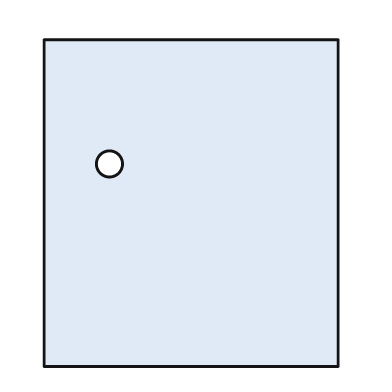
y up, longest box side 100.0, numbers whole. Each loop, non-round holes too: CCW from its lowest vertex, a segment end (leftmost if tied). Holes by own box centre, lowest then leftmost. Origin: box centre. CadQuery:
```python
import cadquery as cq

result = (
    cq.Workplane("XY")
    .moveTo(-45.0, -50.0)
    .lineTo(45.0, -50.0)
    .lineTo(45.0, 50.0)
    .lineTo(-45.0, 50.0)
    .close()
    .moveTo(-25.0, 12.0)
    .circle(4.0)
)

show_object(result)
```